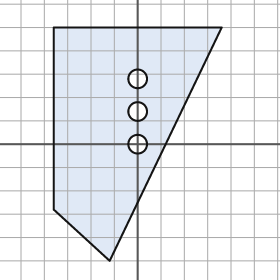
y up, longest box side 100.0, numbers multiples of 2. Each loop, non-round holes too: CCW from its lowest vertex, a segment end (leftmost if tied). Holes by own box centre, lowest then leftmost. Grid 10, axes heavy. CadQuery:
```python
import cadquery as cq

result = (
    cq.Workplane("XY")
    .moveTo(-12.0, -50.0)
    .lineTo(36.0, 50.0)
    .lineTo(-36.0, 50.0)
    .lineTo(-36.0, -28.0)
    .close()
    .moveTo(0.0, 0.0)
    .circle(4.0)
    .moveTo(0.0, 14.0)
    .circle(4.0)
    .moveTo(0.0, 28.0)
    .circle(4.0)
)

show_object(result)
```